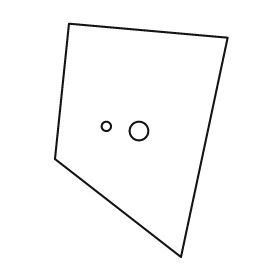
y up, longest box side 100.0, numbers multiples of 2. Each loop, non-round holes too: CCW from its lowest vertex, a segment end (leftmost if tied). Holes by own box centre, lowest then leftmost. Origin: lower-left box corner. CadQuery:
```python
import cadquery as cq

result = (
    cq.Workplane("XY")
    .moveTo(54.0, 0.0)
    .lineTo(74.0, 94.0)
    .lineTo(6.0, 100.0)
    .lineTo(0.0, 42.0)
    .close()
    .moveTo(36.0, 54.0)
    .circle(4.0)
    .moveTo(22.0, 56.0)
    .circle(2.0)
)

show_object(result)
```